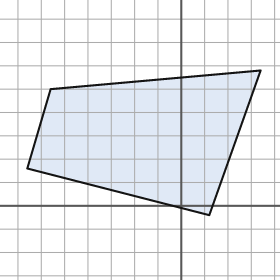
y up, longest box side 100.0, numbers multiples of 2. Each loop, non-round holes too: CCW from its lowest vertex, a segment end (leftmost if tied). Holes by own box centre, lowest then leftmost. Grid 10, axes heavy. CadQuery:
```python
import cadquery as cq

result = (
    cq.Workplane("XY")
    .moveTo(12.0, -4.0)
    .lineTo(34.0, 58.0)
    .lineTo(-56.0, 50.0)
    .lineTo(-66.0, 16.0)
    .close()
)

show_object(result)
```